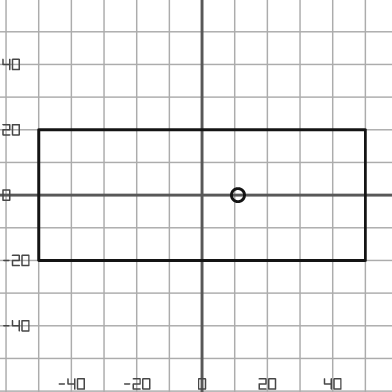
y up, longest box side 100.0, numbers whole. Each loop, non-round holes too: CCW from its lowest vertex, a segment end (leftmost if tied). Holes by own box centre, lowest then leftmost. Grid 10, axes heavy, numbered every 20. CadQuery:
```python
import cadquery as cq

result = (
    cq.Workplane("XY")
    .moveTo(-50.0, -20.0)
    .lineTo(50.0, -20.0)
    .lineTo(50.0, 20.0)
    .lineTo(-50.0, 20.0)
    .close()
    .moveTo(11.0, 0.0)
    .circle(2.0)
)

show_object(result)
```